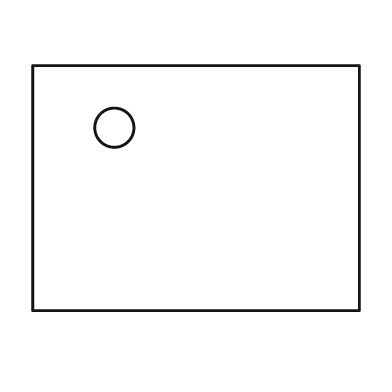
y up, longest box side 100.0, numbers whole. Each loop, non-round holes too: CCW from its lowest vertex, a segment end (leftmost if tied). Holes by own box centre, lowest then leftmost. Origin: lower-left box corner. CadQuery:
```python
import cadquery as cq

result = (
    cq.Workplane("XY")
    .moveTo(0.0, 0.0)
    .lineTo(100.0, 0.0)
    .lineTo(100.0, 75.0)
    .lineTo(0.0, 75.0)
    .close()
    .moveTo(25.0, 56.0)
    .circle(6.0)
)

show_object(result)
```